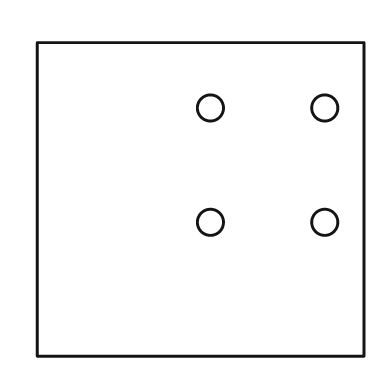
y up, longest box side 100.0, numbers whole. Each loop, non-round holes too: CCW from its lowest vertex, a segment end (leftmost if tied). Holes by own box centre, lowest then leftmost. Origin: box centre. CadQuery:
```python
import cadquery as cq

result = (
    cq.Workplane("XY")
    .moveTo(-50.0, -48.0)
    .lineTo(50.0, -48.0)
    .lineTo(50.0, 48.0)
    .lineTo(-50.0, 48.0)
    .close()
    .moveTo(3.0, -7.0)
    .circle(4.0)
    .moveTo(38.0, -7.0)
    .circle(4.0)
    .moveTo(3.0, 28.0)
    .circle(4.0)
    .moveTo(38.0, 28.0)
    .circle(4.0)
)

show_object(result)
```